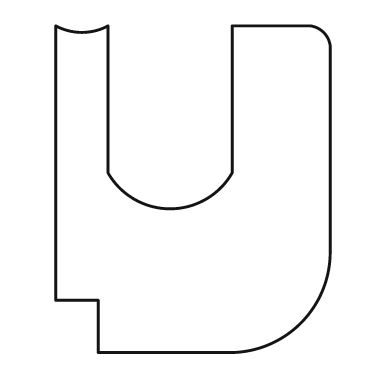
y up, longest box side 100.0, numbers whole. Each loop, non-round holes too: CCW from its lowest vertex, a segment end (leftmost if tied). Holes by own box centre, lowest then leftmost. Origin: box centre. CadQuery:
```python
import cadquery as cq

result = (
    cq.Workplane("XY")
    .moveTo(-29.0, -50.0)
    .lineTo(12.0, -50.0)
    .threePointArc((33.0, -41.0), (42.0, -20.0))
    .lineTo(42.0, 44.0)
    .threePointArc((40.0, 48.0), (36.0, 50.0))
    .lineTo(12.0, 50.0)
    .lineTo(12.0, 5.0)
    .threePointArc((-7.0, -6.0), (-26.0, 5.0))
    .lineTo(-26.0, 50.0)
    .threePointArc((-34.0, 48.0), (-42.0, 50.0))
    .lineTo(-42.0, -34.0)
    .lineTo(-29.0, -34.0)
    .close()
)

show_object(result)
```